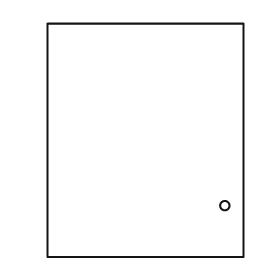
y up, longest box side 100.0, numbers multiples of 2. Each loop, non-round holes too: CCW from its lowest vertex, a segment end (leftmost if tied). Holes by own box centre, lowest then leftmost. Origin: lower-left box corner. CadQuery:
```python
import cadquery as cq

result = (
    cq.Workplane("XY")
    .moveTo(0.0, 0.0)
    .lineTo(84.0, 0.0)
    .lineTo(84.0, 100.0)
    .lineTo(0.0, 100.0)
    .close()
    .moveTo(76.0, 22.0)
    .circle(2.0)
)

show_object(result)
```